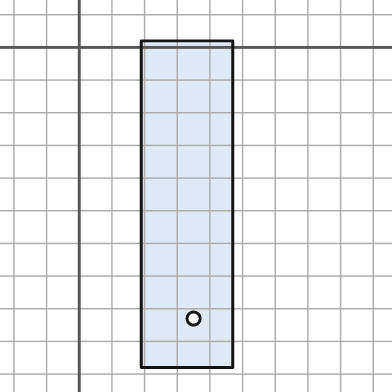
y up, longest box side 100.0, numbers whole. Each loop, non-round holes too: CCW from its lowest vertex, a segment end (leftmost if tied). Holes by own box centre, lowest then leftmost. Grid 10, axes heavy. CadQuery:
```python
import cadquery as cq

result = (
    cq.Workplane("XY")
    .moveTo(19.0, -98.0)
    .lineTo(47.0, -98.0)
    .lineTo(47.0, 2.0)
    .lineTo(19.0, 2.0)
    .close()
    .moveTo(35.0, -83.0)
    .circle(2.0)
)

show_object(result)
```